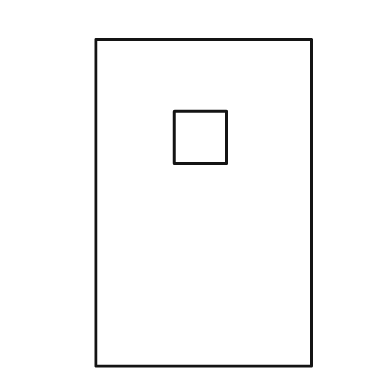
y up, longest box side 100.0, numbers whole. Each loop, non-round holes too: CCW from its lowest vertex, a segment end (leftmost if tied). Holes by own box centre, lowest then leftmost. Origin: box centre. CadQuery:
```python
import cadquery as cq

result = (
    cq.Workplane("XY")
    .moveTo(-33.0, -50.0)
    .lineTo(33.0, -50.0)
    .lineTo(33.0, 50.0)
    .lineTo(-33.0, 50.0)
    .close()
    .moveTo(-9.0, 12.0)
    .lineTo(7.0, 12.0)
    .lineTo(7.0, 28.0)
    .lineTo(-9.0, 28.0)
    .close()
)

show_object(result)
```